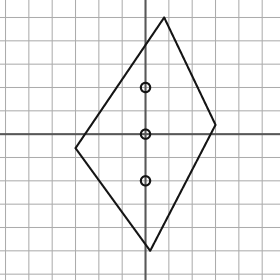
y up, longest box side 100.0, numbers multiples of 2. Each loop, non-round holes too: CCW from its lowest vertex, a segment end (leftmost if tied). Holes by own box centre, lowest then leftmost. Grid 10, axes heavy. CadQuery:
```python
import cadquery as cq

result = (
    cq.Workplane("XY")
    .moveTo(2.0, -50.0)
    .lineTo(30.0, 4.0)
    .lineTo(8.0, 50.0)
    .lineTo(-30.0, -6.0)
    .close()
    .moveTo(0.0, -20.0)
    .circle(2.0)
    .moveTo(0.0, 0.0)
    .circle(2.0)
    .moveTo(0.0, 20.0)
    .circle(2.0)
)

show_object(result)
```